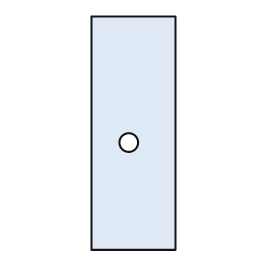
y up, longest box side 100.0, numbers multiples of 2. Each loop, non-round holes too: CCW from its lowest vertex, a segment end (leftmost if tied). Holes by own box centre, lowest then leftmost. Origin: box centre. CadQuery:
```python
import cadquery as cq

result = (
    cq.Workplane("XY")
    .moveTo(-18.0, -50.0)
    .lineTo(18.0, -50.0)
    .lineTo(18.0, 50.0)
    .lineTo(-18.0, 50.0)
    .close()
    .moveTo(-2.0, -4.0)
    .circle(4.0)
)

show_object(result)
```